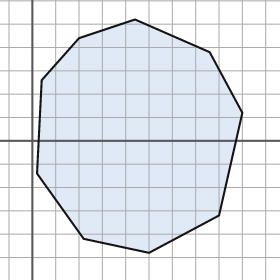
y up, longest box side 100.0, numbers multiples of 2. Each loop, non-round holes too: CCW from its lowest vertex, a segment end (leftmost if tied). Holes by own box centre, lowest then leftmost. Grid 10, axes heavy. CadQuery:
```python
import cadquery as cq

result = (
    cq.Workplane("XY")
    .moveTo(50.0, -48.0)
    .lineTo(80.0, -32.0)
    .lineTo(90.0, 12.0)
    .lineTo(76.0, 38.0)
    .lineTo(44.0, 52.0)
    .lineTo(20.0, 44.0)
    .lineTo(4.0, 26.0)
    .lineTo(2.0, -14.0)
    .lineTo(22.0, -42.0)
    .close()
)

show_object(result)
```